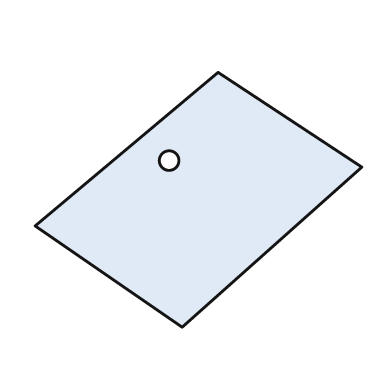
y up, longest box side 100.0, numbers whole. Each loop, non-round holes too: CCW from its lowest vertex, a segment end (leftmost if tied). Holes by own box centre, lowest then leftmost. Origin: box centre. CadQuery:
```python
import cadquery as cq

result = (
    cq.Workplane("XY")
    .moveTo(-5.0, -39.0)
    .lineTo(50.0, 10.0)
    .lineTo(6.0, 39.0)
    .lineTo(-50.0, -8.0)
    .close()
    .moveTo(-9.0, 12.0)
    .circle(3.0)
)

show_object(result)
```